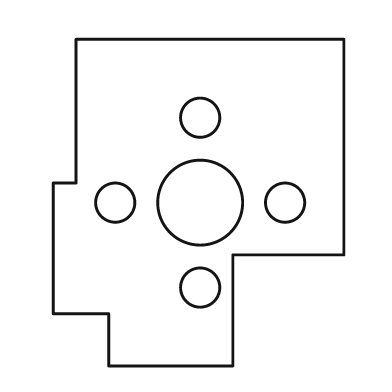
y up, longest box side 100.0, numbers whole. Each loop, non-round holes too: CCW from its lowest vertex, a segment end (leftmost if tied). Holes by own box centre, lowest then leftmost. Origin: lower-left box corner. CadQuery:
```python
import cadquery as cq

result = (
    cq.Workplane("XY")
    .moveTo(17.0, 0.0)
    .lineTo(55.0, 0.0)
    .lineTo(55.0, 34.0)
    .lineTo(89.0, 34.0)
    .lineTo(89.0, 100.0)
    .lineTo(7.0, 100.0)
    .lineTo(7.0, 56.0)
    .lineTo(0.0, 56.0)
    .lineTo(0.0, 16.0)
    .lineTo(17.0, 16.0)
    .close()
    .moveTo(45.0, 24.0)
    .circle(6.0)
    .moveTo(19.0, 50.0)
    .circle(6.0)
    .moveTo(45.0, 50.0)
    .circle(13.0)
    .moveTo(71.0, 50.0)
    .circle(6.0)
    .moveTo(45.0, 76.0)
    .circle(6.0)
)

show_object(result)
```